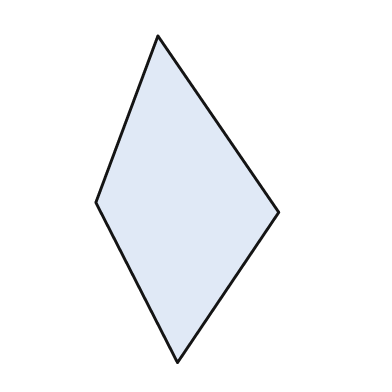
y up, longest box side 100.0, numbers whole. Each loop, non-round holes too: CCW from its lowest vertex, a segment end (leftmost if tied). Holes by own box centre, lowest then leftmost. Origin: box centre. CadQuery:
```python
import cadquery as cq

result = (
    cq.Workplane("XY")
    .moveTo(-3.0, -50.0)
    .lineTo(28.0, -4.0)
    .lineTo(-9.0, 50.0)
    .lineTo(-28.0, -1.0)
    .close()
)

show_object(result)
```